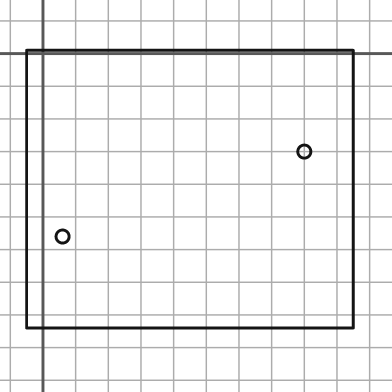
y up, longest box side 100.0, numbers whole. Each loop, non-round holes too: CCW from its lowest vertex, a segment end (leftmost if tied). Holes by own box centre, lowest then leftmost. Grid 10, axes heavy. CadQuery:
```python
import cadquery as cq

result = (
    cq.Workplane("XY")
    .moveTo(-5.0, -84.0)
    .lineTo(95.0, -84.0)
    .lineTo(95.0, 1.0)
    .lineTo(-5.0, 1.0)
    .close()
    .moveTo(6.0, -56.0)
    .circle(2.0)
    .moveTo(80.0, -30.0)
    .circle(2.0)
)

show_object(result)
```